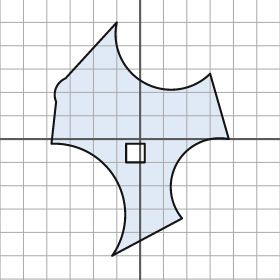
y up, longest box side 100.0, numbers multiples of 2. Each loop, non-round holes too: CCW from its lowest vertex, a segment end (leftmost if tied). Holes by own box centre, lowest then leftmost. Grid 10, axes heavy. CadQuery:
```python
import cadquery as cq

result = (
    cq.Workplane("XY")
    .moveTo(-12.0, -50.0)
    .lineTo(18.0, -34.0)
    .threePointArc((16.0, -10.0), (38.0, 0.0))
    .lineTo(30.0, 28.0)
    .threePointArc((2.0, 24.0), (-10.0, 50.0))
    .lineTo(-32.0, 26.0)
    .threePointArc((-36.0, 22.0), (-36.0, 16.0))
    .lineTo(-38.0, -2.0)
    .threePointArc((-10.0, -18.0), (-12.0, -50.0))
    .close()
    .moveTo(-6.0, -10.0)
    .lineTo(2.0, -10.0)
    .lineTo(2.0, -2.0)
    .lineTo(-6.0, -2.0)
    .close()
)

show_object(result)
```